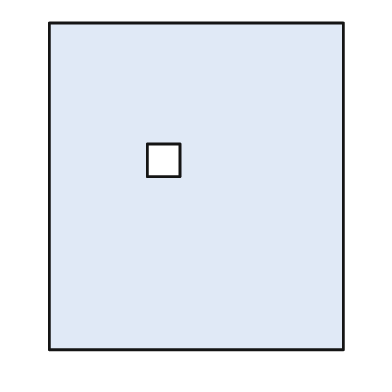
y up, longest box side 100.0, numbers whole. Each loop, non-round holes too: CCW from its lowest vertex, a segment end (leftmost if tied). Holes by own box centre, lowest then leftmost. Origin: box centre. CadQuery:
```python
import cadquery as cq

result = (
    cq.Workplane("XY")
    .moveTo(-45.0, -50.0)
    .lineTo(45.0, -50.0)
    .lineTo(45.0, 50.0)
    .lineTo(-45.0, 50.0)
    .close()
    .moveTo(-15.0, 3.0)
    .lineTo(-5.0, 3.0)
    .lineTo(-5.0, 13.0)
    .lineTo(-15.0, 13.0)
    .close()
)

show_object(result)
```